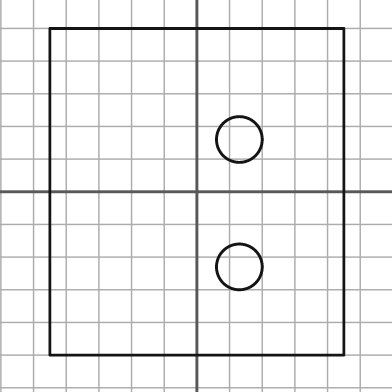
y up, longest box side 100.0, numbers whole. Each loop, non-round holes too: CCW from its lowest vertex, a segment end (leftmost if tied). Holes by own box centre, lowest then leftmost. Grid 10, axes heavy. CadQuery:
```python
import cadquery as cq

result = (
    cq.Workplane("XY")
    .moveTo(-45.0, -50.0)
    .lineTo(45.0, -50.0)
    .lineTo(45.0, 50.0)
    .lineTo(-45.0, 50.0)
    .close()
    .moveTo(13.0, -23.0)
    .circle(7.0)
    .moveTo(13.0, 16.0)
    .circle(7.0)
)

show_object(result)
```